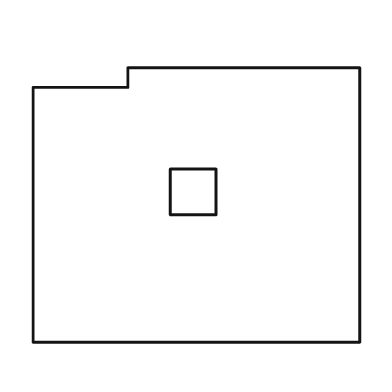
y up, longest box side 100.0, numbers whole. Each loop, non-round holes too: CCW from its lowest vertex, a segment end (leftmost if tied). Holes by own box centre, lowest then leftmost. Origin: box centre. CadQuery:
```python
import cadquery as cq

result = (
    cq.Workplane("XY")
    .moveTo(-50.0, -42.0)
    .lineTo(50.0, -42.0)
    .lineTo(50.0, 42.0)
    .lineTo(-21.0, 42.0)
    .lineTo(-21.0, 36.0)
    .lineTo(-50.0, 36.0)
    .close()
    .moveTo(-8.0, -3.0)
    .lineTo(6.0, -3.0)
    .lineTo(6.0, 11.0)
    .lineTo(-8.0, 11.0)
    .close()
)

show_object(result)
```